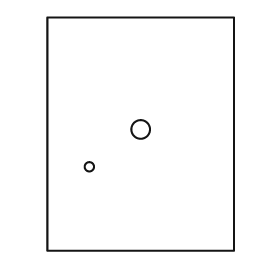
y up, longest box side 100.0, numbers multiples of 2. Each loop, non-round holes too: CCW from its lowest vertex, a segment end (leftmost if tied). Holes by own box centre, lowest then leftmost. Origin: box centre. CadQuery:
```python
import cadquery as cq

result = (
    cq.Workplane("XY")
    .moveTo(-40.0, -50.0)
    .lineTo(40.0, -50.0)
    .lineTo(40.0, 50.0)
    .lineTo(-40.0, 50.0)
    .close()
    .moveTo(-22.0, -14.0)
    .circle(2.0)
    .moveTo(0.0, 2.0)
    .circle(4.0)
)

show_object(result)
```